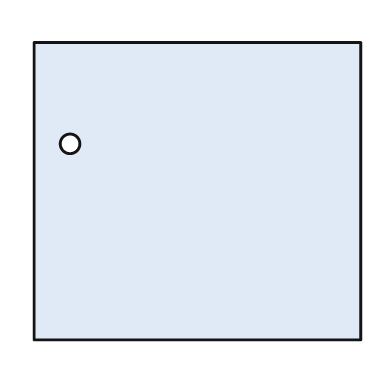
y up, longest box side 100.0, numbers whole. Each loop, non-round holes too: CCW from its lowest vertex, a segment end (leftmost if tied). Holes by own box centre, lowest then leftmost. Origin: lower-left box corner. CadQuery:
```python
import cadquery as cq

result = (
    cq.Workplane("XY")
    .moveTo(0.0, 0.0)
    .lineTo(100.0, 0.0)
    .lineTo(100.0, 91.0)
    .lineTo(0.0, 91.0)
    .close()
    .moveTo(11.0, 60.0)
    .circle(3.0)
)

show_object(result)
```